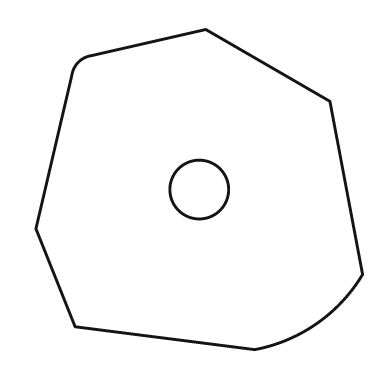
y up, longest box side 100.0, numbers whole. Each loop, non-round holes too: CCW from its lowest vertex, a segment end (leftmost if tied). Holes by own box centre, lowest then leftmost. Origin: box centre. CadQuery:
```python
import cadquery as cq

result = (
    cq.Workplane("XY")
    .moveTo(17.0, -49.0)
    .threePointArc((36.0, -41.0), (50.0, -26.0))
    .lineTo(40.0, 27.0)
    .lineTo(2.0, 49.0)
    .lineTo(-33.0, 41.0)
    .threePointArc((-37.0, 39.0), (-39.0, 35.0))
    .lineTo(-50.0, -12.0)
    .lineTo(-38.0, -42.0)
    .close()
    .moveTo(0.0, 0.0)
    .circle(9.0)
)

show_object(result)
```